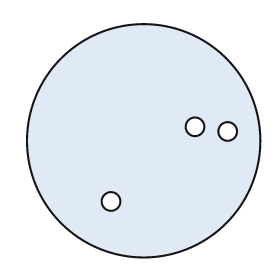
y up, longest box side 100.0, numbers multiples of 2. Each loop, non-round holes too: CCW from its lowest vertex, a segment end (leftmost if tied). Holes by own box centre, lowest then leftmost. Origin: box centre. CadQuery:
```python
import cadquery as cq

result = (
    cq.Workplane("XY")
    .moveTo(0.0, 0.0)
    .circle(50.0)
    .moveTo(-14.0, -26.0)
    .circle(4.0)
    .moveTo(36.0, 4.0)
    .circle(4.0)
    .moveTo(22.0, 6.0)
    .circle(4.0)
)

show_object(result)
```